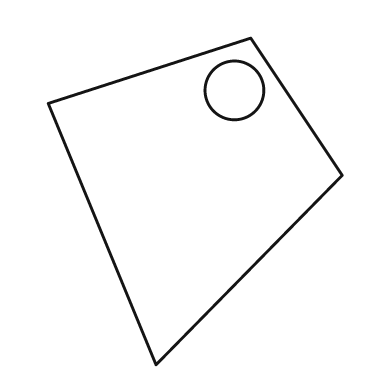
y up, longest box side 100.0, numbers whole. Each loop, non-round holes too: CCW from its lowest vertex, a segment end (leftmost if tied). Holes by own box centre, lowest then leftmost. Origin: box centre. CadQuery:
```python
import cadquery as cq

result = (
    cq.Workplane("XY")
    .moveTo(-12.0, -50.0)
    .lineTo(45.0, 8.0)
    .lineTo(17.0, 50.0)
    .lineTo(-45.0, 30.0)
    .close()
    .moveTo(12.0, 34.0)
    .circle(9.0)
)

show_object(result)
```